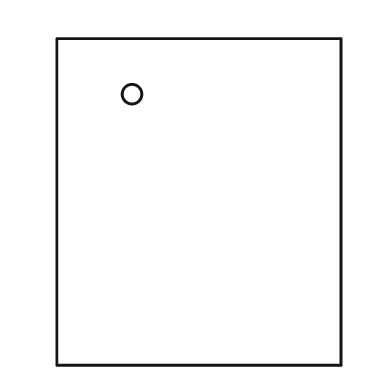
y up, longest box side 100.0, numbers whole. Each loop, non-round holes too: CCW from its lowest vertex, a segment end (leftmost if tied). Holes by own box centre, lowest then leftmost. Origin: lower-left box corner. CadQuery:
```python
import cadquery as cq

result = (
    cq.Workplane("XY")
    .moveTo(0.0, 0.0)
    .lineTo(87.0, 0.0)
    .lineTo(87.0, 100.0)
    .lineTo(0.0, 100.0)
    .close()
    .moveTo(23.0, 83.0)
    .circle(3.0)
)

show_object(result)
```